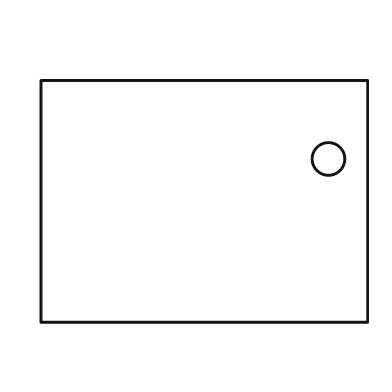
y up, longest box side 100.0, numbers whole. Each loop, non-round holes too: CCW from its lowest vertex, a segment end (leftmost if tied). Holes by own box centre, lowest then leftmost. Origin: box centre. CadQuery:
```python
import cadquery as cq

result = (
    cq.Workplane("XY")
    .moveTo(-50.0, -37.0)
    .lineTo(50.0, -37.0)
    .lineTo(50.0, 37.0)
    .lineTo(-50.0, 37.0)
    .close()
    .moveTo(38.0, 13.0)
    .circle(5.0)
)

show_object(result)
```